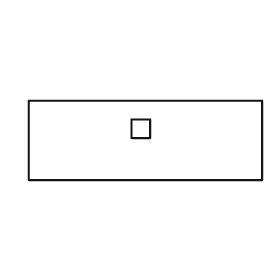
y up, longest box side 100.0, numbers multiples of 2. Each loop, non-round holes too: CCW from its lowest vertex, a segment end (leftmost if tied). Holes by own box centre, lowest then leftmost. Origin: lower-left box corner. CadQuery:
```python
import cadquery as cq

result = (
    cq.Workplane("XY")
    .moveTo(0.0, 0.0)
    .lineTo(100.0, 0.0)
    .lineTo(100.0, 34.0)
    .lineTo(0.0, 34.0)
    .close()
    .moveTo(44.0, 18.0)
    .lineTo(52.0, 18.0)
    .lineTo(52.0, 26.0)
    .lineTo(44.0, 26.0)
    .close()
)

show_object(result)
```